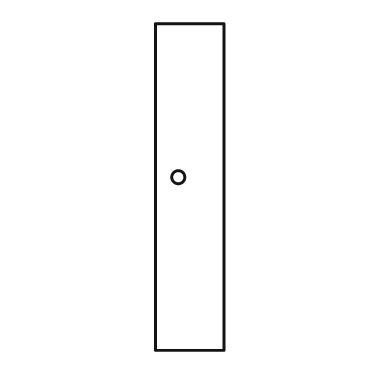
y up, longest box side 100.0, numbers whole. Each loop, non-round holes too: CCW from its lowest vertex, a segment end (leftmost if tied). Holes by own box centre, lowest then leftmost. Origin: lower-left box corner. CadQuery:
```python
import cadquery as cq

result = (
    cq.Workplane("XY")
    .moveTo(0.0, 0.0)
    .lineTo(21.0, 0.0)
    .lineTo(21.0, 100.0)
    .lineTo(0.0, 100.0)
    .close()
    .moveTo(7.0, 53.0)
    .circle(2.0)
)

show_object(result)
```